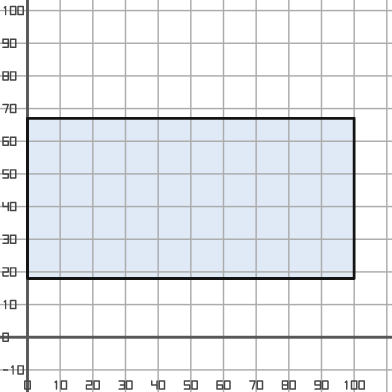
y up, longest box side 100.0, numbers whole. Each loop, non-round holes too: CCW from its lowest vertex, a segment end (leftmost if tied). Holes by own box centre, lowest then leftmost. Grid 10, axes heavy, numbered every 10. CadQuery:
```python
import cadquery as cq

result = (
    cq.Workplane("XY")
    .moveTo(0.0, 18.0)
    .lineTo(100.0, 18.0)
    .lineTo(100.0, 67.0)
    .lineTo(0.0, 67.0)
    .close()
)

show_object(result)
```